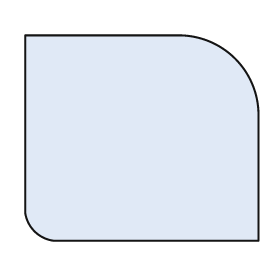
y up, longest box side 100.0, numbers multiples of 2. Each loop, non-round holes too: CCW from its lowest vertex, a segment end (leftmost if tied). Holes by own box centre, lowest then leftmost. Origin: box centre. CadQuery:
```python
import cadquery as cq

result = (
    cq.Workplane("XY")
    .moveTo(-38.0, -44.0)
    .lineTo(50.0, -44.0)
    .lineTo(50.0, 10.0)
    .threePointArc((40.0, 34.0), (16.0, 44.0))
    .lineTo(-50.0, 44.0)
    .lineTo(-50.0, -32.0)
    .threePointArc((-46.0, -40.0), (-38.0, -44.0))
    .close()
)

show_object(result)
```